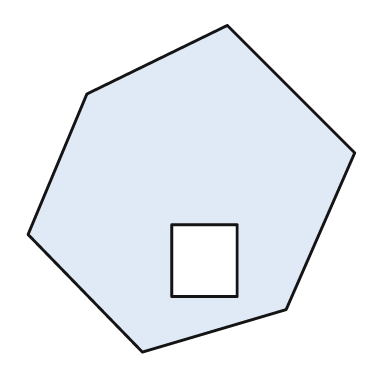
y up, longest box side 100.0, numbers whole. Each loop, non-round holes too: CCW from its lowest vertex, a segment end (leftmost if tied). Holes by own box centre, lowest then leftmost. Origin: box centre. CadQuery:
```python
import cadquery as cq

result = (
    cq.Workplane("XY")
    .moveTo(-15.0, -50.0)
    .lineTo(29.0, -37.0)
    .lineTo(50.0, 11.0)
    .lineTo(11.0, 50.0)
    .lineTo(-32.0, 29.0)
    .lineTo(-50.0, -14.0)
    .close()
    .moveTo(-6.0, -33.0)
    .lineTo(14.0, -33.0)
    .lineTo(14.0, -11.0)
    .lineTo(-6.0, -11.0)
    .close()
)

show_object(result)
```